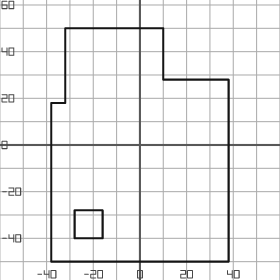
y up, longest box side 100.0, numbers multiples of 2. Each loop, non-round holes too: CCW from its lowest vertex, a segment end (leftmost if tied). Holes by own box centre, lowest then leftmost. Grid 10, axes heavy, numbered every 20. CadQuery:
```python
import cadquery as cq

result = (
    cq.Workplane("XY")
    .moveTo(-38.0, -50.0)
    .lineTo(38.0, -50.0)
    .lineTo(38.0, 28.0)
    .lineTo(10.0, 28.0)
    .lineTo(10.0, 50.0)
    .lineTo(-32.0, 50.0)
    .lineTo(-32.0, 18.0)
    .lineTo(-38.0, 18.0)
    .close()
    .moveTo(-28.0, -40.0)
    .lineTo(-16.0, -40.0)
    .lineTo(-16.0, -28.0)
    .lineTo(-28.0, -28.0)
    .close()
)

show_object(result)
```